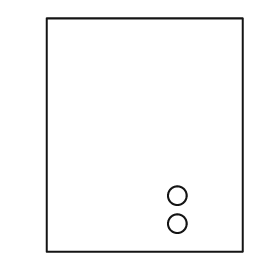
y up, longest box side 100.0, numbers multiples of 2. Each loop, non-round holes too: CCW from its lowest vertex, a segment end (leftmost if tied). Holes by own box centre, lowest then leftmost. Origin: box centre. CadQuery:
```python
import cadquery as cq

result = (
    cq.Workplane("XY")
    .moveTo(-42.0, -50.0)
    .lineTo(42.0, -50.0)
    .lineTo(42.0, 50.0)
    .lineTo(-42.0, 50.0)
    .close()
    .moveTo(14.0, -38.0)
    .circle(4.0)
    .moveTo(14.0, -26.0)
    .circle(4.0)
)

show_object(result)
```